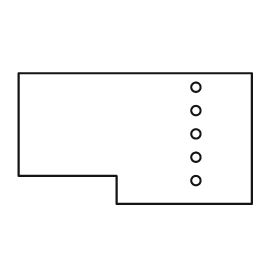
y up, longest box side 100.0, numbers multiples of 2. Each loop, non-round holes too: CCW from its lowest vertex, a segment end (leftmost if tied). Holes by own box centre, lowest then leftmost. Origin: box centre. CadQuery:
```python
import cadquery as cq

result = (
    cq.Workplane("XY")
    .moveTo(-8.0, -28.0)
    .lineTo(50.0, -28.0)
    .lineTo(50.0, 28.0)
    .lineTo(-50.0, 28.0)
    .lineTo(-50.0, -16.0)
    .lineTo(-8.0, -16.0)
    .close()
    .moveTo(26.0, -18.0)
    .circle(2.0)
    .moveTo(26.0, -8.0)
    .circle(2.0)
    .moveTo(26.0, 2.0)
    .circle(2.0)
    .moveTo(26.0, 12.0)
    .circle(2.0)
    .moveTo(26.0, 22.0)
    .circle(2.0)
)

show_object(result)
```